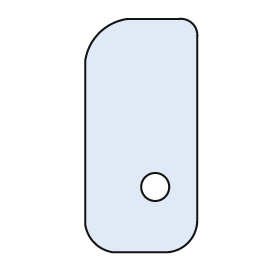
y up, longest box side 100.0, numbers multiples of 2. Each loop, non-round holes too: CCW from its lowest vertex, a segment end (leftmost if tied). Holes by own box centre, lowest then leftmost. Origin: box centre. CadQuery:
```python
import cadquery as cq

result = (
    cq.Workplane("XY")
    .moveTo(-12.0, -50.0)
    .lineTo(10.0, -50.0)
    .threePointArc((20.0, -46.0), (24.0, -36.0))
    .lineTo(24.0, 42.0)
    .threePointArc((22.0, 48.0), (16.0, 50.0))
    .lineTo(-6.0, 50.0)
    .threePointArc((-18.0, 44.0), (-24.0, 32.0))
    .lineTo(-24.0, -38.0)
    .threePointArc((-20.0, -46.0), (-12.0, -50.0))
    .close()
    .moveTo(6.0, -22.0)
    .circle(6.0)
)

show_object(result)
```